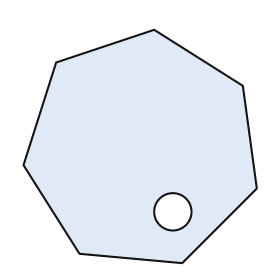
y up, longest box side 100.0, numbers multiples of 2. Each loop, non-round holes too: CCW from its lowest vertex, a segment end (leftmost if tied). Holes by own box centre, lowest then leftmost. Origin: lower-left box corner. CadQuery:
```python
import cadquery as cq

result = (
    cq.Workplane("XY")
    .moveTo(68.0, 0.0)
    .lineTo(100.0, 32.0)
    .lineTo(94.0, 76.0)
    .lineTo(56.0, 100.0)
    .lineTo(14.0, 86.0)
    .lineTo(0.0, 42.0)
    .lineTo(24.0, 4.0)
    .close()
    .moveTo(64.0, 22.0)
    .circle(8.0)
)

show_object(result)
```